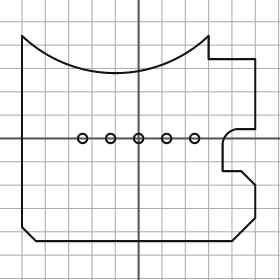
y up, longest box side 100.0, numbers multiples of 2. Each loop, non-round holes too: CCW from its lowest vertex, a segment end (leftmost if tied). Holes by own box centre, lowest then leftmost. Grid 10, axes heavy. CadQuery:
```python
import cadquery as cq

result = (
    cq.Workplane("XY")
    .moveTo(-44.0, -44.0)
    .lineTo(40.0, -44.0)
    .lineTo(50.0, -34.0)
    .lineTo(50.0, -20.0)
    .lineTo(44.0, -14.0)
    .lineTo(36.0, -14.0)
    .lineTo(36.0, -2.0)
    .threePointArc((38.0, 2.0), (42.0, 4.0))
    .lineTo(50.0, 4.0)
    .lineTo(50.0, 34.0)
    .lineTo(30.0, 34.0)
    .lineTo(30.0, 44.0)
    .threePointArc((-10.0, 28.0), (-50.0, 44.0))
    .lineTo(-50.0, -38.0)
    .close()
    .moveTo(-24.0, 0.0)
    .circle(2.0)
    .moveTo(-12.0, 0.0)
    .circle(2.0)
    .moveTo(0.0, 0.0)
    .circle(2.0)
    .moveTo(12.0, 0.0)
    .circle(2.0)
    .moveTo(24.0, 0.0)
    .circle(2.0)
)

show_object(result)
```